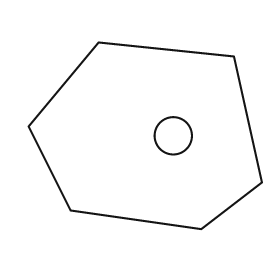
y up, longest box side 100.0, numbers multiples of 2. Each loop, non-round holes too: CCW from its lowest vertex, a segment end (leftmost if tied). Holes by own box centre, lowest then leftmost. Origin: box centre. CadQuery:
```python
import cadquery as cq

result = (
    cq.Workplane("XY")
    .moveTo(24.0, -40.0)
    .lineTo(50.0, -20.0)
    .lineTo(38.0, 34.0)
    .lineTo(-20.0, 40.0)
    .lineTo(-50.0, 4.0)
    .lineTo(-32.0, -32.0)
    .close()
    .moveTo(12.0, 0.0)
    .circle(8.0)
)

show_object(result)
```